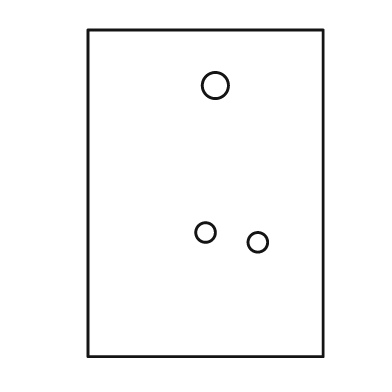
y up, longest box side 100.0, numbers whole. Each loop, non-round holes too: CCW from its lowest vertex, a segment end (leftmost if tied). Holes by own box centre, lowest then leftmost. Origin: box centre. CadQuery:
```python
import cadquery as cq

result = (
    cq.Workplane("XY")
    .moveTo(-36.0, -50.0)
    .lineTo(36.0, -50.0)
    .lineTo(36.0, 50.0)
    .lineTo(-36.0, 50.0)
    .close()
    .moveTo(16.0, -15.0)
    .circle(3.0)
    .moveTo(0.0, -12.0)
    .circle(3.0)
    .moveTo(3.0, 33.0)
    .circle(4.0)
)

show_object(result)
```